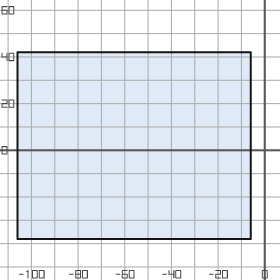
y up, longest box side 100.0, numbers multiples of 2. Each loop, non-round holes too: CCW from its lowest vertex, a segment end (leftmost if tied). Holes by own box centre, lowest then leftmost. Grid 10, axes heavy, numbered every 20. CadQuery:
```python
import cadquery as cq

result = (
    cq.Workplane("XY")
    .moveTo(-106.0, -38.0)
    .lineTo(-6.0, -38.0)
    .lineTo(-6.0, 42.0)
    .lineTo(-106.0, 42.0)
    .close()
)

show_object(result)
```